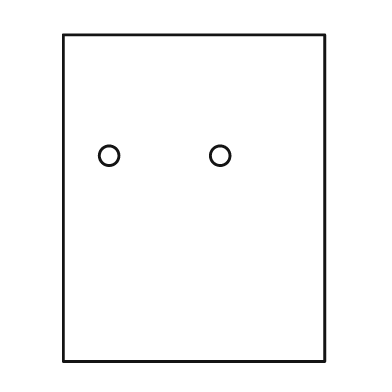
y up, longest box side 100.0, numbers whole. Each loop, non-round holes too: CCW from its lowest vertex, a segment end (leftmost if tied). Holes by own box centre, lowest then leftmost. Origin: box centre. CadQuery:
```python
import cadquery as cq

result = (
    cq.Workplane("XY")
    .moveTo(-40.0, -50.0)
    .lineTo(40.0, -50.0)
    .lineTo(40.0, 50.0)
    .lineTo(-40.0, 50.0)
    .close()
    .moveTo(-26.0, 13.0)
    .circle(3.0)
    .moveTo(8.0, 13.0)
    .circle(3.0)
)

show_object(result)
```